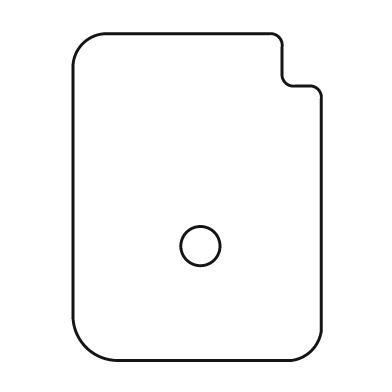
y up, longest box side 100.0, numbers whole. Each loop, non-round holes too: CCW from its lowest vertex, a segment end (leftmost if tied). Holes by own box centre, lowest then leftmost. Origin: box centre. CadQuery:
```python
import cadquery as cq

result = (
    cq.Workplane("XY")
    .moveTo(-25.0, -50.0)
    .lineTo(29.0, -50.0)
    .threePointArc((35.0, -47.0), (38.0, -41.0))
    .lineTo(38.0, 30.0)
    .threePointArc((37.0, 33.0), (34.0, 34.0))
    .lineTo(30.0, 34.0)
    .threePointArc((27.0, 35.0), (26.0, 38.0))
    .lineTo(26.0, 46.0)
    .threePointArc((25.0, 49.0), (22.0, 50.0))
    .lineTo(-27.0, 50.0)
    .threePointArc((-35.0, 47.0), (-38.0, 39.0))
    .lineTo(-38.0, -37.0)
    .threePointArc((-34.0, -46.0), (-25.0, -50.0))
    .close()
    .moveTo(1.0, -15.0)
    .circle(6.0)
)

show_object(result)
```